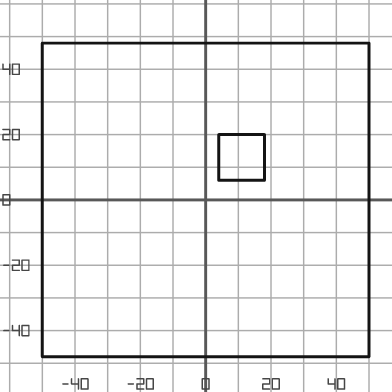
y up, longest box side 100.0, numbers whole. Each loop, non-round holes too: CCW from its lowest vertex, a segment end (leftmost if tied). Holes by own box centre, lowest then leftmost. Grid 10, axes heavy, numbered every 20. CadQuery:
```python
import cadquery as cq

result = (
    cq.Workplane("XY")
    .moveTo(-50.0, -48.0)
    .lineTo(50.0, -48.0)
    .lineTo(50.0, 48.0)
    .lineTo(-50.0, 48.0)
    .close()
    .moveTo(4.0, 6.0)
    .lineTo(18.0, 6.0)
    .lineTo(18.0, 20.0)
    .lineTo(4.0, 20.0)
    .close()
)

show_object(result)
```